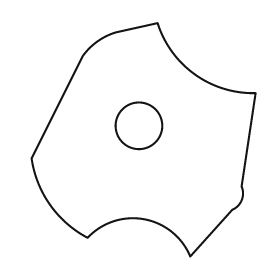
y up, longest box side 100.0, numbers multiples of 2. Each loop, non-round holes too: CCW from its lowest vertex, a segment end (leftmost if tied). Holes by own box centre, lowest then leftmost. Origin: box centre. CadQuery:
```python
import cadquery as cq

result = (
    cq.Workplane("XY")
    .moveTo(20.0, -50.0)
    .lineTo(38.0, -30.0)
    .threePointArc((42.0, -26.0), (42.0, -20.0))
    .lineTo(48.0, 20.0)
    .threePointArc((22.0, 28.0), (6.0, 50.0))
    .lineTo(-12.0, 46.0)
    .threePointArc((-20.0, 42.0), (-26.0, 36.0))
    .lineTo(-48.0, -8.0)
    .threePointArc((-40.0, -28.0), (-24.0, -42.0))
    .threePointArc((0.0, -34.0), (20.0, -50.0))
    .close()
    .moveTo(-2.0, 6.0)
    .circle(10.0)
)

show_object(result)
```